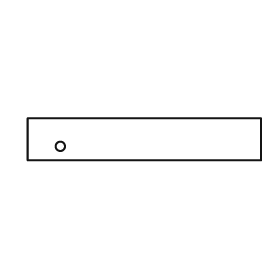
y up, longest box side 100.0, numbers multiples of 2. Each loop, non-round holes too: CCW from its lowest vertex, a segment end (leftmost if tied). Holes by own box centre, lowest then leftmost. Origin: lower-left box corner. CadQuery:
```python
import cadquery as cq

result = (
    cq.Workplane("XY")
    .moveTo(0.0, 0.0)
    .lineTo(100.0, 0.0)
    .lineTo(100.0, 18.0)
    .lineTo(0.0, 18.0)
    .close()
    .moveTo(14.0, 6.0)
    .circle(2.0)
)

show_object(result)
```